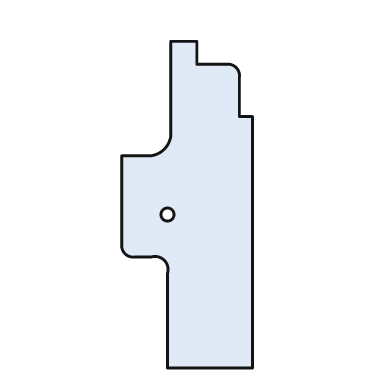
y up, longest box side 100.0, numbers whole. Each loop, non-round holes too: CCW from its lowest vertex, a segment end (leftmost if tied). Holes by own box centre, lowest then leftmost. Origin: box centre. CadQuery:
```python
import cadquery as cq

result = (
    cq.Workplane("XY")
    .moveTo(-6.0, -50.0)
    .lineTo(20.0, -50.0)
    .lineTo(20.0, 27.0)
    .lineTo(16.0, 27.0)
    .lineTo(16.0, 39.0)
    .threePointArc((15.0, 42.0), (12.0, 43.0))
    .lineTo(3.0, 43.0)
    .lineTo(3.0, 50.0)
    .lineTo(-5.0, 50.0)
    .lineTo(-5.0, 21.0)
    .threePointArc((-7.0, 17.0), (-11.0, 15.0))
    .lineTo(-20.0, 15.0)
    .lineTo(-20.0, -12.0)
    .threePointArc((-19.0, -15.0), (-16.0, -16.0))
    .lineTo(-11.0, -16.0)
    .threePointArc((-7.0, -17.0), (-6.0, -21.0))
    .close()
    .moveTo(-6.0, -3.0)
    .circle(2.0)
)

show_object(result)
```